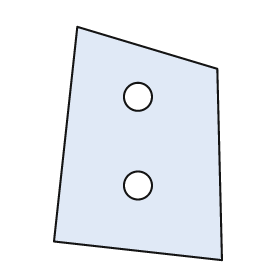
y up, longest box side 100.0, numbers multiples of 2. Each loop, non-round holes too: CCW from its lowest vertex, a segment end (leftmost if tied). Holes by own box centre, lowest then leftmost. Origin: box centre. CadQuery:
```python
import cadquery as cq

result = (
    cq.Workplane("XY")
    .moveTo(36.0, -50.0)
    .lineTo(34.0, 32.0)
    .lineTo(-26.0, 50.0)
    .lineTo(-36.0, -42.0)
    .close()
    .moveTo(0.0, -18.0)
    .circle(6.0)
    .moveTo(0.0, 20.0)
    .circle(6.0)
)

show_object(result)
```